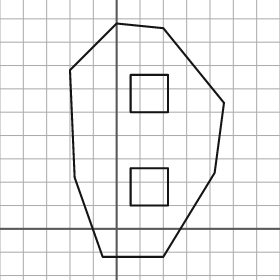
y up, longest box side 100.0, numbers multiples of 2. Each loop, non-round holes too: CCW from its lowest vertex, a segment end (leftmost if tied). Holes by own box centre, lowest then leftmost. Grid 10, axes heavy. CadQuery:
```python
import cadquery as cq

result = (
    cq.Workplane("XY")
    .moveTo(-6.0, -12.0)
    .lineTo(20.0, -12.0)
    .lineTo(42.0, 24.0)
    .lineTo(46.0, 54.0)
    .lineTo(20.0, 86.0)
    .lineTo(0.0, 88.0)
    .lineTo(-20.0, 68.0)
    .lineTo(-18.0, 22.0)
    .close()
    .moveTo(6.0, 10.0)
    .lineTo(22.0, 10.0)
    .lineTo(22.0, 26.0)
    .lineTo(6.0, 26.0)
    .close()
    .moveTo(6.0, 50.0)
    .lineTo(22.0, 50.0)
    .lineTo(22.0, 66.0)
    .lineTo(6.0, 66.0)
    .close()
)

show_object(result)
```